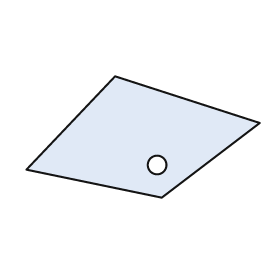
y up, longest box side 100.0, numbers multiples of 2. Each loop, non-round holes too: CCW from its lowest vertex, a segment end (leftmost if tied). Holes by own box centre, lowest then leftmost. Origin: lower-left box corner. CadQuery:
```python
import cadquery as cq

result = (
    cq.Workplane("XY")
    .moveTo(58.0, 0.0)
    .lineTo(100.0, 32.0)
    .lineTo(38.0, 52.0)
    .lineTo(0.0, 12.0)
    .close()
    .moveTo(56.0, 14.0)
    .circle(4.0)
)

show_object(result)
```